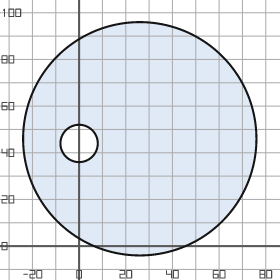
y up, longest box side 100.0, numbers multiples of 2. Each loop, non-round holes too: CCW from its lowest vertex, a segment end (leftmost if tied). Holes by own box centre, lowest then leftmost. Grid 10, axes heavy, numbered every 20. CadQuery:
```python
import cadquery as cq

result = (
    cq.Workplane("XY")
    .moveTo(26.0, 46.0)
    .circle(50.0)
    .moveTo(0.0, 44.0)
    .circle(8.0)
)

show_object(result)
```